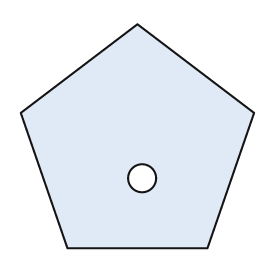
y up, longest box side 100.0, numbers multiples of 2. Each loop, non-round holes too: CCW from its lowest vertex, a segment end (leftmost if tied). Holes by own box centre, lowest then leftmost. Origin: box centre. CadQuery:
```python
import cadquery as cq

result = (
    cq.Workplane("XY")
    .moveTo(-30.0, -48.0)
    .lineTo(30.0, -48.0)
    .lineTo(50.0, 10.0)
    .lineTo(0.0, 48.0)
    .lineTo(-50.0, 10.0)
    .close()
    .moveTo(2.0, -18.0)
    .circle(6.0)
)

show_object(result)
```